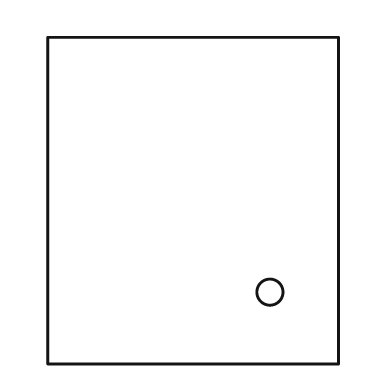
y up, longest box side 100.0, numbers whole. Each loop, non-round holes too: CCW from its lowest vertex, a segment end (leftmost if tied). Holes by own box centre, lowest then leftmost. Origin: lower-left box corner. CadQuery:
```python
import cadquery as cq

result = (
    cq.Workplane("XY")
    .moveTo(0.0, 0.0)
    .lineTo(89.0, 0.0)
    .lineTo(89.0, 100.0)
    .lineTo(0.0, 100.0)
    .close()
    .moveTo(68.0, 22.0)
    .circle(4.0)
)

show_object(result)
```